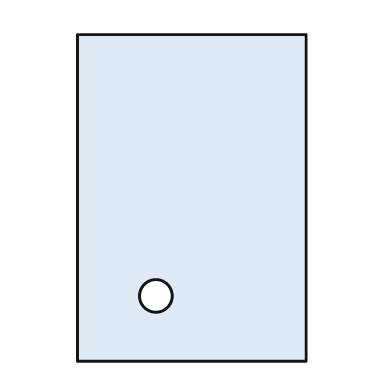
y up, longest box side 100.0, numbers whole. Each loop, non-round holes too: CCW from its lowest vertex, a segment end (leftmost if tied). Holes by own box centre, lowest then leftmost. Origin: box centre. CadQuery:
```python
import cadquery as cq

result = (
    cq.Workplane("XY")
    .moveTo(-35.0, -50.0)
    .lineTo(35.0, -50.0)
    .lineTo(35.0, 50.0)
    .lineTo(-35.0, 50.0)
    .close()
    .moveTo(-11.0, -30.0)
    .circle(5.0)
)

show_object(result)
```